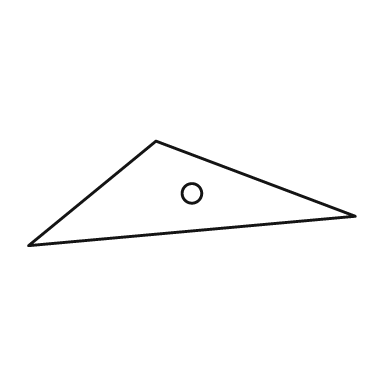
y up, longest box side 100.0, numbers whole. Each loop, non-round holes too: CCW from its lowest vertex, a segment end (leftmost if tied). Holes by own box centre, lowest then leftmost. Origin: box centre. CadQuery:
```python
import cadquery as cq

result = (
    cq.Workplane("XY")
    .moveTo(-50.0, -16.0)
    .lineTo(50.0, -7.0)
    .lineTo(-11.0, 16.0)
    .close()
    .moveTo(0.0, 0.0)
    .circle(3.0)
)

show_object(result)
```